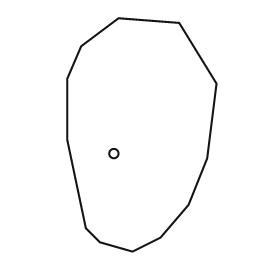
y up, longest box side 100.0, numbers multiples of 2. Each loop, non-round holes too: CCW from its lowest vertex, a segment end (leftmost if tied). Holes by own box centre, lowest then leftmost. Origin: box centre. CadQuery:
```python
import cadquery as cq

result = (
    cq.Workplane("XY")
    .moveTo(-4.0, -50.0)
    .lineTo(8.0, -44.0)
    .lineTo(20.0, -30.0)
    .lineTo(28.0, -10.0)
    .lineTo(32.0, 22.0)
    .lineTo(16.0, 48.0)
    .lineTo(-10.0, 50.0)
    .lineTo(-26.0, 38.0)
    .lineTo(-32.0, 24.0)
    .lineTo(-32.0, -2.0)
    .lineTo(-24.0, -40.0)
    .lineTo(-18.0, -46.0)
    .close()
    .moveTo(-12.0, -8.0)
    .circle(2.0)
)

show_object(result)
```